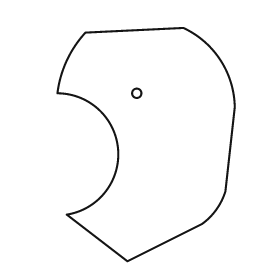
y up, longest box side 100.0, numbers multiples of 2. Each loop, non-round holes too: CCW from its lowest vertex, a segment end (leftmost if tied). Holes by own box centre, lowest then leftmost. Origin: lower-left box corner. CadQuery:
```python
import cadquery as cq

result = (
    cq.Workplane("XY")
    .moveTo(30.0, 0.0)
    .lineTo(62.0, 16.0)
    .threePointArc((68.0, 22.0), (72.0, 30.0))
    .lineTo(76.0, 66.0)
    .threePointArc((70.0, 86.0), (54.0, 100.0))
    .lineTo(12.0, 98.0)
    .threePointArc((4.0, 86.0), (0.0, 72.0))
    .threePointArc((26.0, 48.0), (4.0, 20.0))
    .close()
    .moveTo(34.0, 72.0)
    .circle(2.0)
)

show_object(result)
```